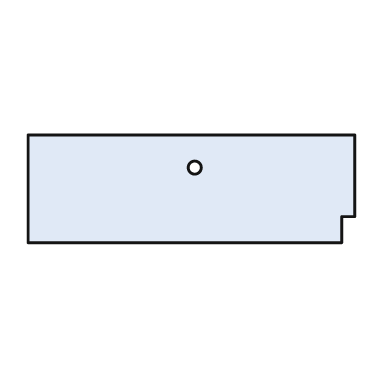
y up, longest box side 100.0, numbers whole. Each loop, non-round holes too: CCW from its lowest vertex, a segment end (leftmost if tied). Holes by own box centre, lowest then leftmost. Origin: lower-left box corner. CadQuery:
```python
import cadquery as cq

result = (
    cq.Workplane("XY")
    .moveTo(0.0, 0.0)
    .lineTo(96.0, 0.0)
    .lineTo(96.0, 8.0)
    .lineTo(100.0, 8.0)
    .lineTo(100.0, 33.0)
    .lineTo(0.0, 33.0)
    .close()
    .moveTo(51.0, 23.0)
    .circle(2.0)
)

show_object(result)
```